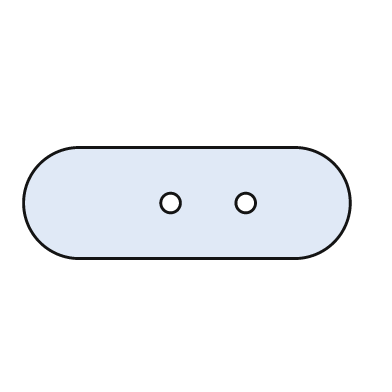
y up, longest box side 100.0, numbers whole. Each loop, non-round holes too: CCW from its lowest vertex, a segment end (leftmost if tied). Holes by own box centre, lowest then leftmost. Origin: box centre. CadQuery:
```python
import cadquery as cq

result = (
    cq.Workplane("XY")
    .moveTo(-33.0, -17.0)
    .lineTo(33.0, -17.0)
    .threePointArc((50.0, 0.0), (33.0, 17.0))
    .lineTo(-33.0, 17.0)
    .threePointArc((-50.0, 0.0), (-33.0, -17.0))
    .close()
    .moveTo(-5.0, 0.0)
    .circle(3.0)
    .moveTo(18.0, 0.0)
    .circle(3.0)
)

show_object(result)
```